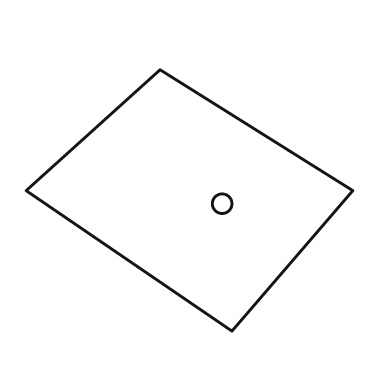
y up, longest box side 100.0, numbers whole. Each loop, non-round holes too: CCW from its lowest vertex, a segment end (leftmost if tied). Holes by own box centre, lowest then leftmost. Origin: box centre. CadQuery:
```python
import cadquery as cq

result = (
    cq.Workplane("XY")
    .moveTo(13.0, -40.0)
    .lineTo(50.0, 3.0)
    .lineTo(-9.0, 40.0)
    .lineTo(-50.0, 3.0)
    .close()
    .moveTo(10.0, -1.0)
    .circle(3.0)
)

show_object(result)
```